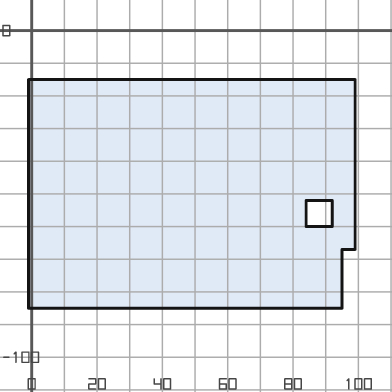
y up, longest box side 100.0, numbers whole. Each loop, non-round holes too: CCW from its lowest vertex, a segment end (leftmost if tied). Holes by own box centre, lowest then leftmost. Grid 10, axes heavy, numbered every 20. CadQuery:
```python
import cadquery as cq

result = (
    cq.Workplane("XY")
    .moveTo(-1.0, -85.0)
    .lineTo(95.0, -85.0)
    .lineTo(95.0, -67.0)
    .lineTo(99.0, -67.0)
    .lineTo(99.0, -15.0)
    .lineTo(-1.0, -15.0)
    .close()
    .moveTo(84.0, -60.0)
    .lineTo(92.0, -60.0)
    .lineTo(92.0, -52.0)
    .lineTo(84.0, -52.0)
    .close()
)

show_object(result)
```